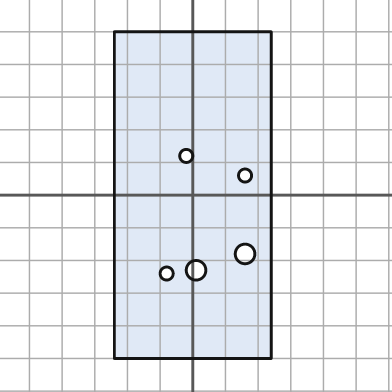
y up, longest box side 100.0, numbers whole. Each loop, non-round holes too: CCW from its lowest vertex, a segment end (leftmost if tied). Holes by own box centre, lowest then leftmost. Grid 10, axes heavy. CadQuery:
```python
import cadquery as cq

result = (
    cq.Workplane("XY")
    .moveTo(-24.0, -50.0)
    .lineTo(24.0, -50.0)
    .lineTo(24.0, 50.0)
    .lineTo(-24.0, 50.0)
    .close()
    .moveTo(-8.0, -24.0)
    .circle(2.0)
    .moveTo(1.0, -23.0)
    .circle(3.0)
    .moveTo(16.0, -18.0)
    .circle(3.0)
    .moveTo(16.0, 6.0)
    .circle(2.0)
    .moveTo(-2.0, 12.0)
    .circle(2.0)
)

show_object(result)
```